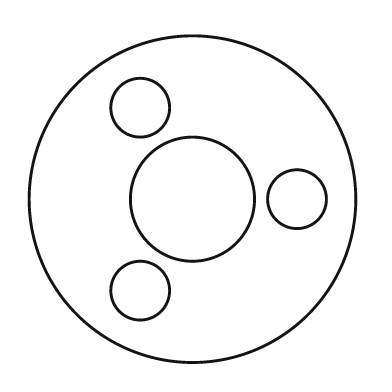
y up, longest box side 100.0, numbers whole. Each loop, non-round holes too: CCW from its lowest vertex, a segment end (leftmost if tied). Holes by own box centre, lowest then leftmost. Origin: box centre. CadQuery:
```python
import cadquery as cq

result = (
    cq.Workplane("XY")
    .moveTo(0.0, 0.0)
    .circle(50.0)
    .moveTo(-16.0, -28.0)
    .circle(9.0)
    .moveTo(0.0, 0.0)
    .circle(19.0)
    .moveTo(32.0, 0.0)
    .circle(9.0)
    .moveTo(-16.0, 28.0)
    .circle(9.0)
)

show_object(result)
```